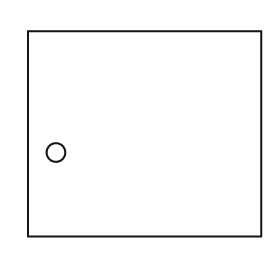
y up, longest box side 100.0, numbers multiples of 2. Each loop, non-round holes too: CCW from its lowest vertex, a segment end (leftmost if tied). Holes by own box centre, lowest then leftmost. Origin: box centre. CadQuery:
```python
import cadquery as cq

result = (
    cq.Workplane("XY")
    .moveTo(-50.0, -44.0)
    .lineTo(50.0, -44.0)
    .lineTo(50.0, 44.0)
    .lineTo(-50.0, 44.0)
    .close()
    .moveTo(-38.0, -8.0)
    .circle(4.0)
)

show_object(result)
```